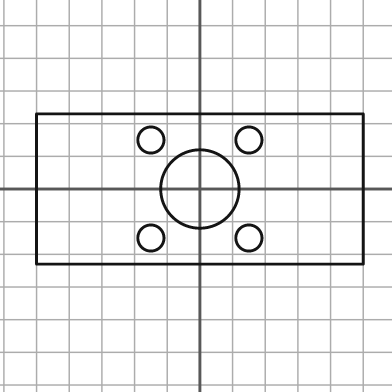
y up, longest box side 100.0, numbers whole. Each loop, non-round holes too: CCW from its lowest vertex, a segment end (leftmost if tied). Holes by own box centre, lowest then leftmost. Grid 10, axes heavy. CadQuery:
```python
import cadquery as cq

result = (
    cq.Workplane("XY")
    .moveTo(-50.0, -23.0)
    .lineTo(50.0, -23.0)
    .lineTo(50.0, 23.0)
    .lineTo(-50.0, 23.0)
    .close()
    .moveTo(-15.0, -15.0)
    .circle(4.0)
    .moveTo(15.0, -15.0)
    .circle(4.0)
    .moveTo(0.0, 0.0)
    .circle(12.0)
    .moveTo(-15.0, 15.0)
    .circle(4.0)
    .moveTo(15.0, 15.0)
    .circle(4.0)
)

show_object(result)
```